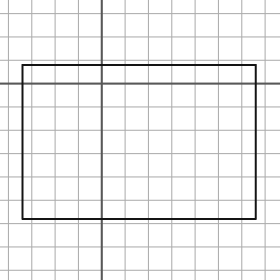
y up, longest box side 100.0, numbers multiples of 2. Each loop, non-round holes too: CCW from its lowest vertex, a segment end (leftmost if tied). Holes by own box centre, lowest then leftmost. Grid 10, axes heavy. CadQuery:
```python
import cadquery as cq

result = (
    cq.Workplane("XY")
    .moveTo(-34.0, -58.0)
    .lineTo(66.0, -58.0)
    .lineTo(66.0, 8.0)
    .lineTo(-34.0, 8.0)
    .close()
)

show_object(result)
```